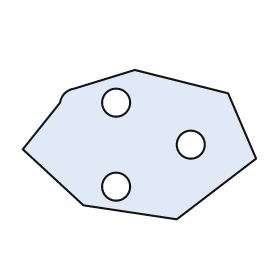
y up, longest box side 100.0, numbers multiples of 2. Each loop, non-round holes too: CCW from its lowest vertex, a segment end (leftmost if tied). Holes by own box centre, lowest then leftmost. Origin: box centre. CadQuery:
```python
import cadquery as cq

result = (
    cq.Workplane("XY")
    .moveTo(16.0, -32.0)
    .lineTo(50.0, -6.0)
    .lineTo(38.0, 22.0)
    .lineTo(-2.0, 32.0)
    .lineTo(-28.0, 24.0)
    .threePointArc((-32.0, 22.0), (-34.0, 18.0))
    .lineTo(-50.0, -2.0)
    .lineTo(-24.0, -26.0)
    .close()
    .moveTo(-10.0, -18.0)
    .circle(6.0)
    .moveTo(22.0, 0.0)
    .circle(6.0)
    .moveTo(-10.0, 18.0)
    .circle(6.0)
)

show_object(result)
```